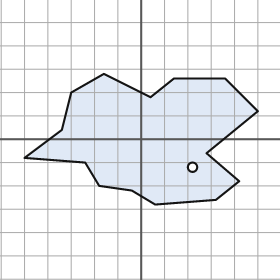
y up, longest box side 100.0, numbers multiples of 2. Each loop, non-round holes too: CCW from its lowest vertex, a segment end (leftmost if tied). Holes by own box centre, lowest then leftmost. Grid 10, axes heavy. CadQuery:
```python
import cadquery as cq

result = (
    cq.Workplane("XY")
    .moveTo(6.0, -28.0)
    .lineTo(32.0, -26.0)
    .lineTo(42.0, -18.0)
    .lineTo(28.0, -6.0)
    .lineTo(50.0, 12.0)
    .lineTo(36.0, 26.0)
    .lineTo(14.0, 26.0)
    .lineTo(4.0, 18.0)
    .lineTo(-16.0, 28.0)
    .lineTo(-30.0, 20.0)
    .lineTo(-34.0, 4.0)
    .lineTo(-50.0, -8.0)
    .lineTo(-24.0, -10.0)
    .lineTo(-18.0, -20.0)
    .lineTo(-4.0, -22.0)
    .close()
    .moveTo(22.0, -12.0)
    .circle(2.0)
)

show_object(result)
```